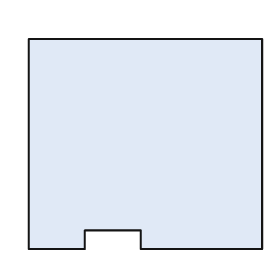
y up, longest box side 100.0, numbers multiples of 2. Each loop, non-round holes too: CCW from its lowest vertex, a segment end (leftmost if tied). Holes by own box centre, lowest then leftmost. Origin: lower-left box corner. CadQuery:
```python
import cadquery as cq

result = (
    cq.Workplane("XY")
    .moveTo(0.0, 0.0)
    .lineTo(24.0, 0.0)
    .lineTo(24.0, 8.0)
    .lineTo(48.0, 8.0)
    .lineTo(48.0, 0.0)
    .lineTo(100.0, 0.0)
    .lineTo(100.0, 90.0)
    .lineTo(0.0, 90.0)
    .close()
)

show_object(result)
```